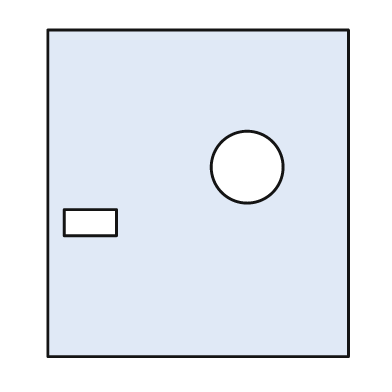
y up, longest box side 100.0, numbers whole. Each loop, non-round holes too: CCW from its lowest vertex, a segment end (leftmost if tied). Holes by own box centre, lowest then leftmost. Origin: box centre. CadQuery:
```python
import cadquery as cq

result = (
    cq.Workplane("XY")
    .moveTo(-46.0, -50.0)
    .lineTo(46.0, -50.0)
    .lineTo(46.0, 50.0)
    .lineTo(-46.0, 50.0)
    .close()
    .moveTo(-41.0, -13.0)
    .lineTo(-25.0, -13.0)
    .lineTo(-25.0, -5.0)
    .lineTo(-41.0, -5.0)
    .close()
    .moveTo(15.0, 8.0)
    .circle(11.0)
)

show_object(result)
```